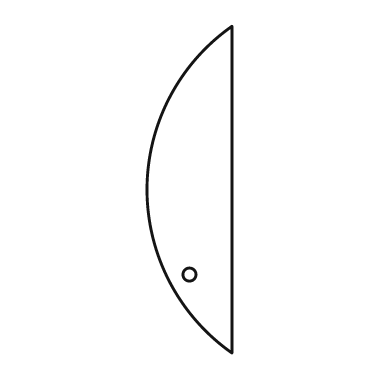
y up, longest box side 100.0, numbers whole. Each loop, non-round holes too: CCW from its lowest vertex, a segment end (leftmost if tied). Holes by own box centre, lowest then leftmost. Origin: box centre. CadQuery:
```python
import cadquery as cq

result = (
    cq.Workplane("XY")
    .moveTo(13.0, -50.0)
    .lineTo(13.0, 50.0)
    .threePointArc((-13.0, 0.0), (13.0, -50.0))
    .close()
    .moveTo(0.0, -26.0)
    .circle(2.0)
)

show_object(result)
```